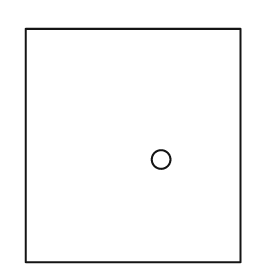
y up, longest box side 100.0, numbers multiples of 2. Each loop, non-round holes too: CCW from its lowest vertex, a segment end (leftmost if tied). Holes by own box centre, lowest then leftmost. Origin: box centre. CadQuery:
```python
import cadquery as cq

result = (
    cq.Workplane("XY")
    .moveTo(-46.0, -50.0)
    .lineTo(46.0, -50.0)
    .lineTo(46.0, 50.0)
    .lineTo(-46.0, 50.0)
    .close()
    .moveTo(12.0, -6.0)
    .circle(4.0)
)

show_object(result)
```